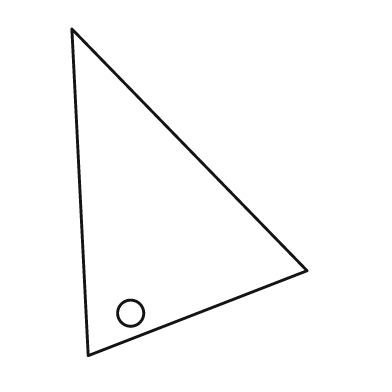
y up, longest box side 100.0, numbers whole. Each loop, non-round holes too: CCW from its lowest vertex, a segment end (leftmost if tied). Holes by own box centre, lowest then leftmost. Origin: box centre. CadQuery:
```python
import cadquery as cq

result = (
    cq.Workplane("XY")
    .moveTo(-31.0, -50.0)
    .lineTo(36.0, -24.0)
    .lineTo(-36.0, 50.0)
    .close()
    .moveTo(-18.0, -37.0)
    .circle(4.0)
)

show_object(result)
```